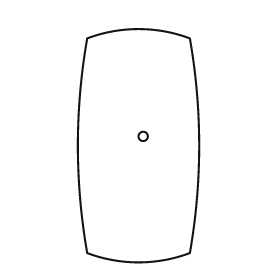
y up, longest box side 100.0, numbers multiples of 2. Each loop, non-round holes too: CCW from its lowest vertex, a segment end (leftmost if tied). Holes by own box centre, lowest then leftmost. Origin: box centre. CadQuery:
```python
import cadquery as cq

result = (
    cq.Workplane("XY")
    .moveTo(-22.0, -46.0)
    .threePointArc((0.0, -50.0), (22.0, -46.0))
    .threePointArc((26.0, 0.0), (22.0, 46.0))
    .threePointArc((0.0, 50.0), (-22.0, 46.0))
    .threePointArc((-26.0, 0.0), (-22.0, -46.0))
    .close()
    .moveTo(2.0, 4.0)
    .circle(2.0)
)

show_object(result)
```